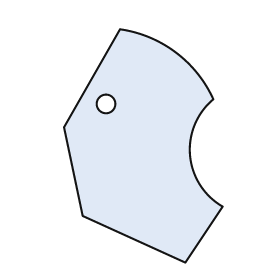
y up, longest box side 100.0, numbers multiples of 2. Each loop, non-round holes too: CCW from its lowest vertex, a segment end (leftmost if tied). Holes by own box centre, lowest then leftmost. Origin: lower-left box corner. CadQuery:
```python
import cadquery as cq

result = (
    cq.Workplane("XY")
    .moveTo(52.0, 0.0)
    .lineTo(68.0, 24.0)
    .threePointArc((54.0, 46.0), (64.0, 70.0))
    .threePointArc((48.0, 90.0), (24.0, 100.0))
    .lineTo(0.0, 58.0)
    .lineTo(8.0, 20.0)
    .close()
    .moveTo(18.0, 68.0)
    .circle(4.0)
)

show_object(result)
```